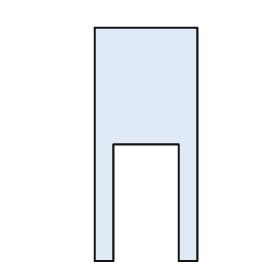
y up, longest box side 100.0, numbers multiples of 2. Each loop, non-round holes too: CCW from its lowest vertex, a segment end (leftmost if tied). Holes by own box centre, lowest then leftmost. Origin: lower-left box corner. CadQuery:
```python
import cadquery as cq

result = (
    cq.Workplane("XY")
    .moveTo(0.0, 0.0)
    .lineTo(8.0, 0.0)
    .lineTo(8.0, 50.0)
    .lineTo(36.0, 50.0)
    .lineTo(36.0, 0.0)
    .lineTo(44.0, 0.0)
    .lineTo(44.0, 100.0)
    .lineTo(0.0, 100.0)
    .close()
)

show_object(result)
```